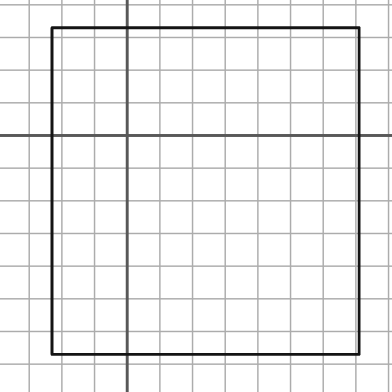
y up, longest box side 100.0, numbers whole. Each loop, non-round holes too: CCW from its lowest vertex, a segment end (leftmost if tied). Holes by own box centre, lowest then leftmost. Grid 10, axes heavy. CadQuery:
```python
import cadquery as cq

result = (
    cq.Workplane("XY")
    .moveTo(-23.0, -67.0)
    .lineTo(71.0, -67.0)
    .lineTo(71.0, 33.0)
    .lineTo(-23.0, 33.0)
    .close()
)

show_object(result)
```